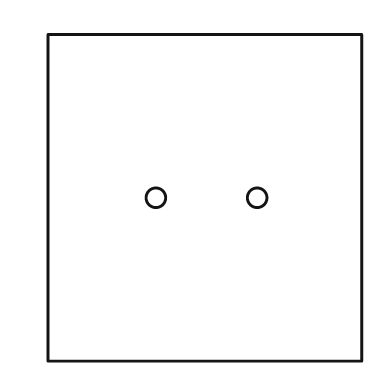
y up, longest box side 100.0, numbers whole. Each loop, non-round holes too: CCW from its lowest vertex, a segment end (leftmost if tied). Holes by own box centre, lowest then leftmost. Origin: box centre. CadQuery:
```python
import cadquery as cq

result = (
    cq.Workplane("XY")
    .moveTo(-48.0, -50.0)
    .lineTo(48.0, -50.0)
    .lineTo(48.0, 50.0)
    .lineTo(-48.0, 50.0)
    .close()
    .moveTo(-15.0, 0.0)
    .circle(3.0)
    .moveTo(16.0, 0.0)
    .circle(3.0)
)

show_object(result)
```